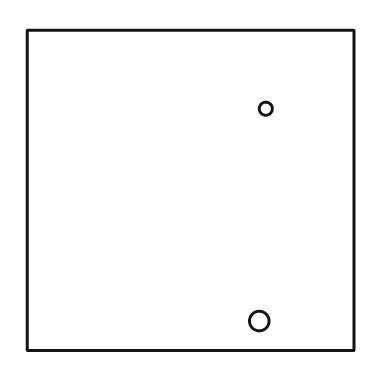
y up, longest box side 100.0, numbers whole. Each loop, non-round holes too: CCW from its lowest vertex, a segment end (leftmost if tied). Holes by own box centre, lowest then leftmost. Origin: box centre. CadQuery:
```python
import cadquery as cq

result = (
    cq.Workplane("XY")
    .moveTo(-50.0, -49.0)
    .lineTo(50.0, -49.0)
    .lineTo(50.0, 49.0)
    .lineTo(-50.0, 49.0)
    .close()
    .moveTo(21.0, -40.0)
    .circle(3.0)
    .moveTo(23.0, 25.0)
    .circle(2.0)
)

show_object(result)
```